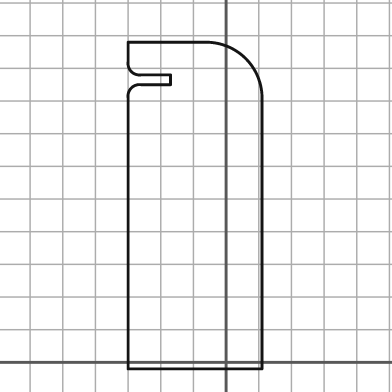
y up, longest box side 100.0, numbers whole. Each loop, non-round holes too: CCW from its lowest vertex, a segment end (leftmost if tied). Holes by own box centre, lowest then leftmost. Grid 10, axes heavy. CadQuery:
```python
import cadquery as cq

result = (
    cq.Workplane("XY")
    .moveTo(-30.0, -2.0)
    .lineTo(11.0, -2.0)
    .lineTo(11.0, 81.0)
    .threePointArc((6.0, 93.0), (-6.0, 98.0))
    .lineTo(-30.0, 98.0)
    .lineTo(-30.0, 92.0)
    .threePointArc((-29.0, 89.0), (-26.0, 88.0))
    .lineTo(-17.0, 88.0)
    .lineTo(-17.0, 85.0)
    .lineTo(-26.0, 85.0)
    .threePointArc((-29.0, 84.0), (-30.0, 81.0))
    .close()
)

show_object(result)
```